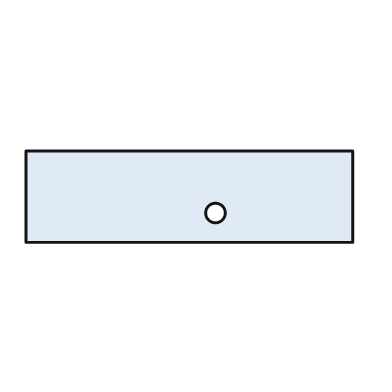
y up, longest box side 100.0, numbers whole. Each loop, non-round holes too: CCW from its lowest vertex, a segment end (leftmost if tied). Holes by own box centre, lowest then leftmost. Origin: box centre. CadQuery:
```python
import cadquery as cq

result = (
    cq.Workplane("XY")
    .moveTo(-50.0, -14.0)
    .lineTo(50.0, -14.0)
    .lineTo(50.0, 14.0)
    .lineTo(-50.0, 14.0)
    .close()
    .moveTo(8.0, -5.0)
    .circle(3.0)
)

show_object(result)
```